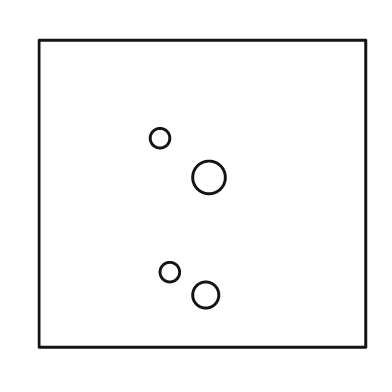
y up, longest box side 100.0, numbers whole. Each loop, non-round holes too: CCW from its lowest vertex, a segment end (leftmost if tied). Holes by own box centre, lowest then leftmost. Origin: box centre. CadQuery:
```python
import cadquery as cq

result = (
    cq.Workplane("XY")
    .moveTo(-50.0, -47.0)
    .lineTo(50.0, -47.0)
    .lineTo(50.0, 47.0)
    .lineTo(-50.0, 47.0)
    .close()
    .moveTo(1.0, -31.0)
    .circle(4.0)
    .moveTo(-10.0, -24.0)
    .circle(3.0)
    .moveTo(2.0, 5.0)
    .circle(5.0)
    .moveTo(-13.0, 17.0)
    .circle(3.0)
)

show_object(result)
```